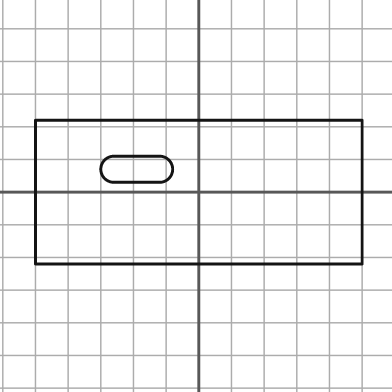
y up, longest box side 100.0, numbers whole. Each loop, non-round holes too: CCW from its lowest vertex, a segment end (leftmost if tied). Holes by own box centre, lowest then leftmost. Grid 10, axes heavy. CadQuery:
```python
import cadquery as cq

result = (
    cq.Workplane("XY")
    .moveTo(-50.0, -22.0)
    .lineTo(50.0, -22.0)
    .lineTo(50.0, 22.0)
    .lineTo(-50.0, 22.0)
    .close()
    .moveTo(-26.0, 3.0)
    .lineTo(-12.0, 3.0)
    .threePointArc((-8.0, 7.0), (-12.0, 11.0))
    .lineTo(-26.0, 11.0)
    .threePointArc((-30.0, 7.0), (-26.0, 3.0))
    .close()
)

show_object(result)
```